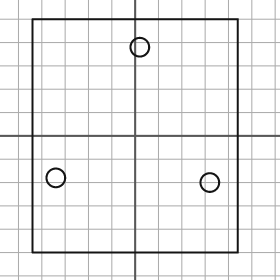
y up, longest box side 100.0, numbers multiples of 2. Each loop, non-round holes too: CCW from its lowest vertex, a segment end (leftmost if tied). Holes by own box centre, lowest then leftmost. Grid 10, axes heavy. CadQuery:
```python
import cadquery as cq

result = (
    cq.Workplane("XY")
    .moveTo(-44.0, -50.0)
    .lineTo(44.0, -50.0)
    .lineTo(44.0, 50.0)
    .lineTo(-44.0, 50.0)
    .close()
    .moveTo(32.0, -20.0)
    .circle(4.0)
    .moveTo(-34.0, -18.0)
    .circle(4.0)
    .moveTo(2.0, 38.0)
    .circle(4.0)
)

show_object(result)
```